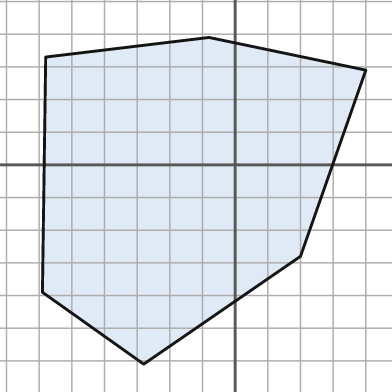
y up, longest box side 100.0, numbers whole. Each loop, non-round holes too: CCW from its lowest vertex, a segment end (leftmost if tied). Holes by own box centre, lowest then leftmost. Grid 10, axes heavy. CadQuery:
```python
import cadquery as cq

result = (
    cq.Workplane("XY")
    .moveTo(-28.0, -61.0)
    .lineTo(20.0, -28.0)
    .lineTo(40.0, 29.0)
    .lineTo(-8.0, 39.0)
    .lineTo(-58.0, 33.0)
    .lineTo(-59.0, -39.0)
    .close()
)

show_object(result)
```